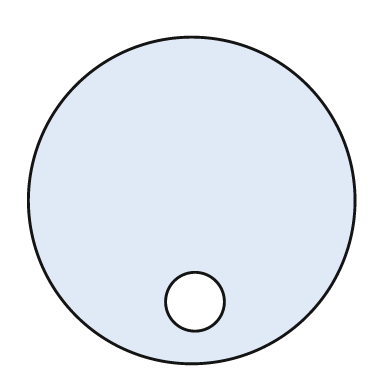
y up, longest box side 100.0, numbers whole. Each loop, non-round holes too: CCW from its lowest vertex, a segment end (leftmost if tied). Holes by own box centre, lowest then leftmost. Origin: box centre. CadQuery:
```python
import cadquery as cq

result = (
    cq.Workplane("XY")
    .moveTo(0.0, 0.0)
    .circle(50.0)
    .moveTo(1.0, -31.0)
    .circle(9.0)
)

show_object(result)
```